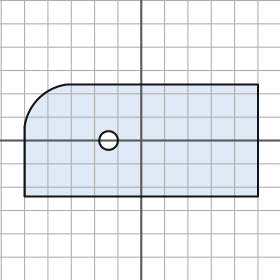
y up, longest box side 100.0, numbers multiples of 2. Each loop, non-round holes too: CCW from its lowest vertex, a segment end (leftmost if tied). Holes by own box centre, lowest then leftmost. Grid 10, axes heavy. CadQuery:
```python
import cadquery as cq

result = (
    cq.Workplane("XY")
    .moveTo(-50.0, -24.0)
    .lineTo(50.0, -24.0)
    .lineTo(50.0, 24.0)
    .lineTo(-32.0, 24.0)
    .threePointArc((-44.0, 18.0), (-50.0, 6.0))
    .close()
    .moveTo(-14.0, 0.0)
    .circle(4.0)
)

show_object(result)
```